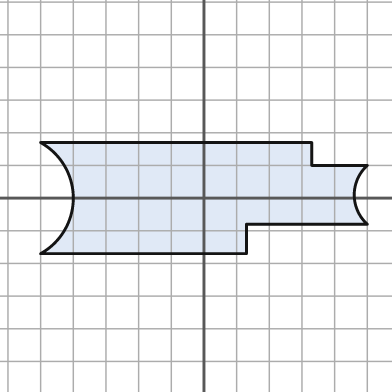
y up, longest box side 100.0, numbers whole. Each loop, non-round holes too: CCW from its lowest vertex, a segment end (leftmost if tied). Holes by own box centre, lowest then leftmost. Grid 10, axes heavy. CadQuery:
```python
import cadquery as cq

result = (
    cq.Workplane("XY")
    .moveTo(-50.0, -17.0)
    .lineTo(13.0, -17.0)
    .lineTo(13.0, -8.0)
    .lineTo(50.0, -8.0)
    .threePointArc((46.0, 1.0), (50.0, 10.0))
    .lineTo(33.0, 10.0)
    .lineTo(33.0, 17.0)
    .lineTo(-50.0, 17.0)
    .threePointArc((-40.0, 0.0), (-50.0, -17.0))
    .close()
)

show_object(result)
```